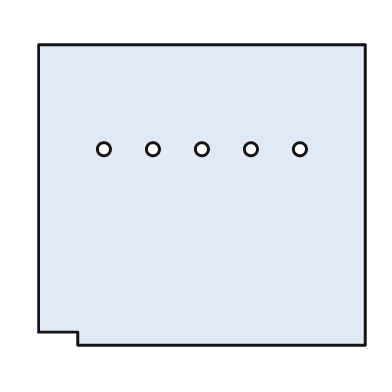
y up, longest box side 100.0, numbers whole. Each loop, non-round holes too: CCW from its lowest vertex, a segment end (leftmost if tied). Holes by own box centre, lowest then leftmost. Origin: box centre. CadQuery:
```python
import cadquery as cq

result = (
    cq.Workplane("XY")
    .moveTo(-38.0, -46.0)
    .lineTo(50.0, -46.0)
    .lineTo(50.0, 46.0)
    .lineTo(-50.0, 46.0)
    .lineTo(-50.0, -42.0)
    .lineTo(-38.0, -42.0)
    .close()
    .moveTo(-30.0, 14.0)
    .circle(2.0)
    .moveTo(-15.0, 14.0)
    .circle(2.0)
    .moveTo(0.0, 14.0)
    .circle(2.0)
    .moveTo(15.0, 14.0)
    .circle(2.0)
    .moveTo(30.0, 14.0)
    .circle(2.0)
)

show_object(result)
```